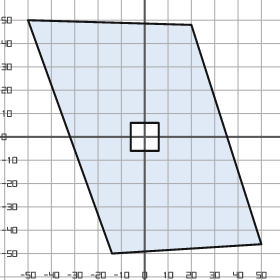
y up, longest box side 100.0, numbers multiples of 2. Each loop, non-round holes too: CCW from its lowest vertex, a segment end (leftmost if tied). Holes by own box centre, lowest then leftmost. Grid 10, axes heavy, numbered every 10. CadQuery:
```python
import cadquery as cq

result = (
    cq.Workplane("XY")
    .moveTo(-14.0, -50.0)
    .lineTo(50.0, -46.0)
    .lineTo(20.0, 48.0)
    .lineTo(-50.0, 50.0)
    .close()
    .moveTo(-6.0, -6.0)
    .lineTo(6.0, -6.0)
    .lineTo(6.0, 6.0)
    .lineTo(-6.0, 6.0)
    .close()
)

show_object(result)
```